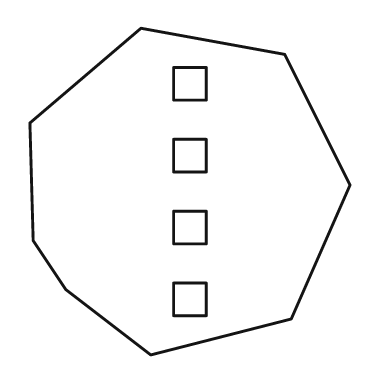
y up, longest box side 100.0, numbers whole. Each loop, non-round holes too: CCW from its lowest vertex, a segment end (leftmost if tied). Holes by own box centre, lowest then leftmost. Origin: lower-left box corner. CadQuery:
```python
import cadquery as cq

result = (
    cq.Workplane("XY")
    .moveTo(37.0, 0.0)
    .lineTo(80.0, 11.0)
    .lineTo(98.0, 52.0)
    .lineTo(78.0, 92.0)
    .lineTo(34.0, 100.0)
    .lineTo(0.0, 71.0)
    .lineTo(1.0, 35.0)
    .lineTo(11.0, 20.0)
    .close()
    .moveTo(44.0, 12.0)
    .lineTo(54.0, 12.0)
    .lineTo(54.0, 22.0)
    .lineTo(44.0, 22.0)
    .close()
    .moveTo(44.0, 34.0)
    .lineTo(54.0, 34.0)
    .lineTo(54.0, 44.0)
    .lineTo(44.0, 44.0)
    .close()
    .moveTo(44.0, 56.0)
    .lineTo(54.0, 56.0)
    .lineTo(54.0, 66.0)
    .lineTo(44.0, 66.0)
    .close()
    .moveTo(44.0, 78.0)
    .lineTo(54.0, 78.0)
    .lineTo(54.0, 88.0)
    .lineTo(44.0, 88.0)
    .close()
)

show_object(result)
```